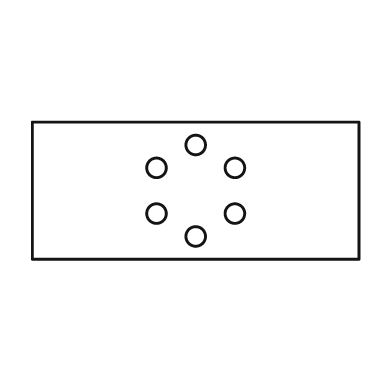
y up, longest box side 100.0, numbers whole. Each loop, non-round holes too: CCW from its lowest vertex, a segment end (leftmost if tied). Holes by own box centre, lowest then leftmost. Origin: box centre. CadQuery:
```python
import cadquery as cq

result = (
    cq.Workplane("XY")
    .moveTo(-50.0, -21.0)
    .lineTo(50.0, -21.0)
    .lineTo(50.0, 21.0)
    .lineTo(-50.0, 21.0)
    .close()
    .moveTo(0.0, -14.0)
    .circle(3.0)
    .moveTo(-12.0, -7.0)
    .circle(3.0)
    .moveTo(12.0, -7.0)
    .circle(3.0)
    .moveTo(-12.0, 7.0)
    .circle(3.0)
    .moveTo(12.0, 7.0)
    .circle(3.0)
    .moveTo(0.0, 14.0)
    .circle(3.0)
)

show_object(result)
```